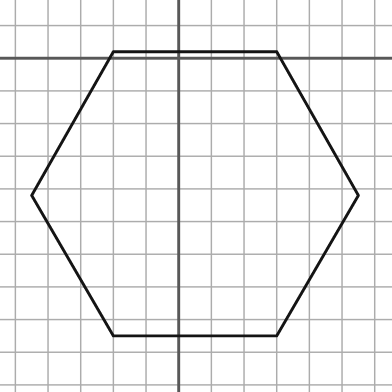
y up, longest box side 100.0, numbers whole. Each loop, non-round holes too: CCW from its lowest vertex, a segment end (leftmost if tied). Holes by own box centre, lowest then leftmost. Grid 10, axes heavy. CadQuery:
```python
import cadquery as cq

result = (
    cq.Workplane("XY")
    .moveTo(-20.0, -85.0)
    .lineTo(30.0, -85.0)
    .lineTo(55.0, -42.0)
    .lineTo(30.0, 2.0)
    .lineTo(-20.0, 2.0)
    .lineTo(-45.0, -42.0)
    .close()
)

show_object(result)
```